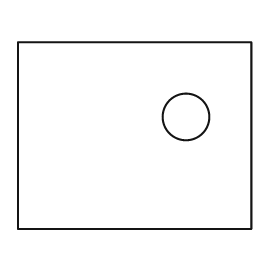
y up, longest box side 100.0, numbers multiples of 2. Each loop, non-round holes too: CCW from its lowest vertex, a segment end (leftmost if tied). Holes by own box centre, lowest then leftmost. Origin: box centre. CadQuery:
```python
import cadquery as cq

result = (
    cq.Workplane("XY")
    .moveTo(-50.0, -40.0)
    .lineTo(50.0, -40.0)
    .lineTo(50.0, 40.0)
    .lineTo(-50.0, 40.0)
    .close()
    .moveTo(22.0, 8.0)
    .circle(10.0)
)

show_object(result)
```